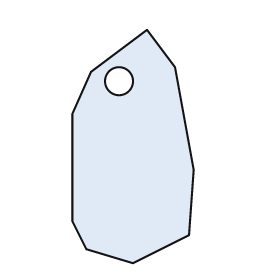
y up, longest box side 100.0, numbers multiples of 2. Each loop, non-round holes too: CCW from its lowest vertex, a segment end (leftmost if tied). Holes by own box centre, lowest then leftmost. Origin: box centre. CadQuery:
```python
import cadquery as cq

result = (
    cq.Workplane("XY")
    .moveTo(0.0, -50.0)
    .lineTo(24.0, -38.0)
    .lineTo(26.0, -10.0)
    .lineTo(18.0, 34.0)
    .lineTo(6.0, 50.0)
    .lineTo(-18.0, 32.0)
    .lineTo(-26.0, 14.0)
    .lineTo(-26.0, -32.0)
    .lineTo(-20.0, -44.0)
    .close()
    .moveTo(-6.0, 28.0)
    .circle(6.0)
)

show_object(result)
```